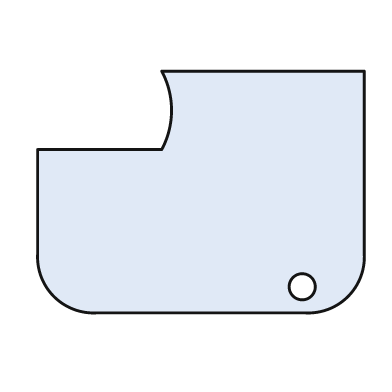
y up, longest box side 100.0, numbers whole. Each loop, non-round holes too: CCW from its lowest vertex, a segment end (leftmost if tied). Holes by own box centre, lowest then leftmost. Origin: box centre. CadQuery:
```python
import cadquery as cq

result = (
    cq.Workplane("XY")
    .moveTo(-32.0, -37.0)
    .lineTo(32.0, -37.0)
    .threePointArc((45.0, -32.0), (50.0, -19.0))
    .lineTo(50.0, 37.0)
    .lineTo(-12.0, 37.0)
    .threePointArc((-9.0, 25.0), (-12.0, 13.0))
    .lineTo(-50.0, 13.0)
    .lineTo(-50.0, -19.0)
    .threePointArc((-45.0, -32.0), (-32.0, -37.0))
    .close()
    .moveTo(31.0, -29.0)
    .circle(4.0)
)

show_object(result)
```